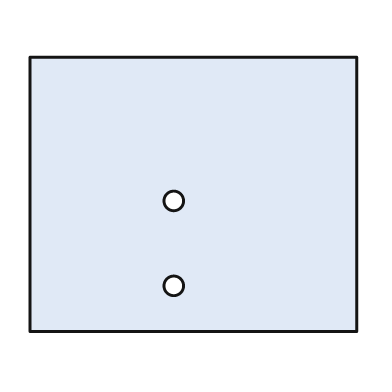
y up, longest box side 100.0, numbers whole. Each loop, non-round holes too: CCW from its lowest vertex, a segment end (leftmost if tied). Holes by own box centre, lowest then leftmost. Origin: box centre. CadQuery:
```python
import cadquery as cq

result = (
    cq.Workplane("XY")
    .moveTo(-50.0, -42.0)
    .lineTo(50.0, -42.0)
    .lineTo(50.0, 42.0)
    .lineTo(-50.0, 42.0)
    .close()
    .moveTo(-6.0, -28.0)
    .circle(3.0)
    .moveTo(-6.0, -2.0)
    .circle(3.0)
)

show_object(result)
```